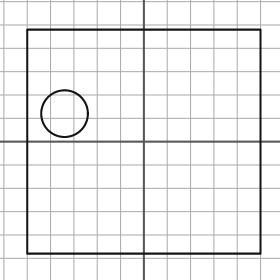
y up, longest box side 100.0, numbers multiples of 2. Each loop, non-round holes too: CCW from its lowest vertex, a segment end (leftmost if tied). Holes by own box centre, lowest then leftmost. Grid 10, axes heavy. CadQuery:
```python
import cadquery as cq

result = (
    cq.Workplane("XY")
    .moveTo(-50.0, -48.0)
    .lineTo(50.0, -48.0)
    .lineTo(50.0, 48.0)
    .lineTo(-50.0, 48.0)
    .close()
    .moveTo(-34.0, 12.0)
    .circle(10.0)
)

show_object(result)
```